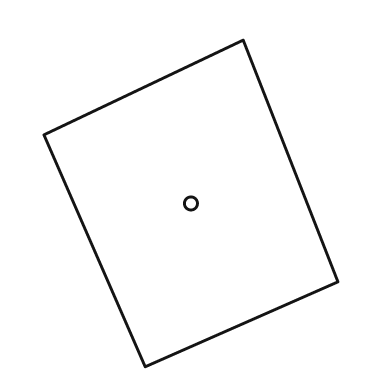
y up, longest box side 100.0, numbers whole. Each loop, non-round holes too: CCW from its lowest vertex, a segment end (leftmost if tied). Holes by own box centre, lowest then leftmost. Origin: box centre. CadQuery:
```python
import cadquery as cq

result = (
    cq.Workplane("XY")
    .moveTo(-14.0, -50.0)
    .lineTo(45.0, -24.0)
    .lineTo(16.0, 50.0)
    .lineTo(-45.0, 21.0)
    .close()
    .moveTo(0.0, 0.0)
    .circle(2.0)
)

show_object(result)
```